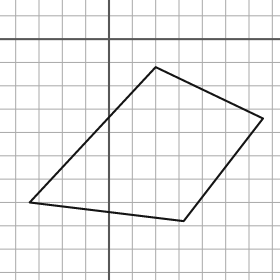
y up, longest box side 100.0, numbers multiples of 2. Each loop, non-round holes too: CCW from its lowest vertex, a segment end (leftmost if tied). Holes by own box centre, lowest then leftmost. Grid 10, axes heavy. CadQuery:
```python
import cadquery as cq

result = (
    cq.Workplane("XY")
    .moveTo(32.0, -78.0)
    .lineTo(66.0, -34.0)
    .lineTo(20.0, -12.0)
    .lineTo(-34.0, -70.0)
    .close()
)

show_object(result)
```